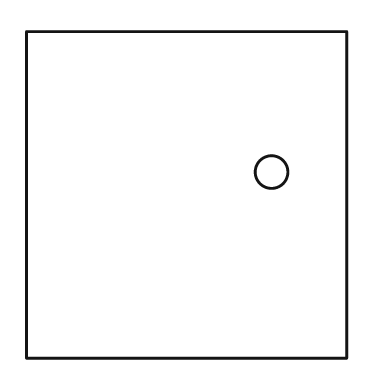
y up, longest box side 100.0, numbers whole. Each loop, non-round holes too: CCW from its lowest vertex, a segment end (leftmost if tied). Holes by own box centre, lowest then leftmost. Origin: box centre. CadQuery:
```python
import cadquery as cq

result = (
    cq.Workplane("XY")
    .moveTo(-49.0, -50.0)
    .lineTo(49.0, -50.0)
    .lineTo(49.0, 50.0)
    .lineTo(-49.0, 50.0)
    .close()
    .moveTo(26.0, 7.0)
    .circle(5.0)
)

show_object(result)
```